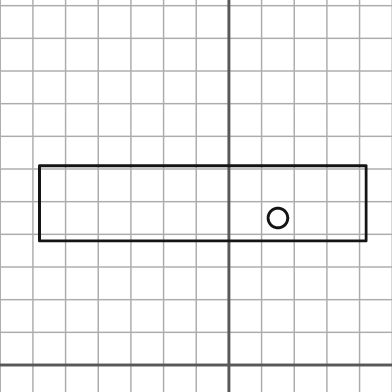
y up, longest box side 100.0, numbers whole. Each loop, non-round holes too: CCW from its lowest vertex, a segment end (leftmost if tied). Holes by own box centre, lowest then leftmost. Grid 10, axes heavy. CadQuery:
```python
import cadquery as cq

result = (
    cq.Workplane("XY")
    .moveTo(-58.0, 38.0)
    .lineTo(42.0, 38.0)
    .lineTo(42.0, 61.0)
    .lineTo(-58.0, 61.0)
    .close()
    .moveTo(15.0, 45.0)
    .circle(3.0)
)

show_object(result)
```